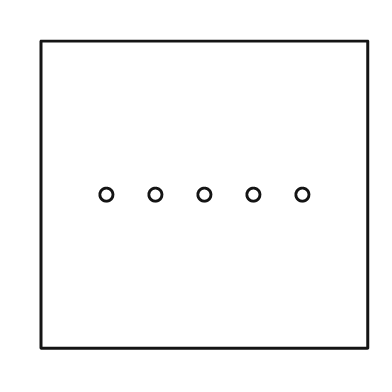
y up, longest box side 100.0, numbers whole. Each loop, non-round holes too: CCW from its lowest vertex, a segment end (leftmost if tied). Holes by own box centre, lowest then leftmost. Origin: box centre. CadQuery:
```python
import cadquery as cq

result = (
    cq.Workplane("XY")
    .moveTo(-50.0, -47.0)
    .lineTo(50.0, -47.0)
    .lineTo(50.0, 47.0)
    .lineTo(-50.0, 47.0)
    .close()
    .moveTo(-30.0, 0.0)
    .circle(2.0)
    .moveTo(-15.0, 0.0)
    .circle(2.0)
    .moveTo(0.0, 0.0)
    .circle(2.0)
    .moveTo(15.0, 0.0)
    .circle(2.0)
    .moveTo(30.0, 0.0)
    .circle(2.0)
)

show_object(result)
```